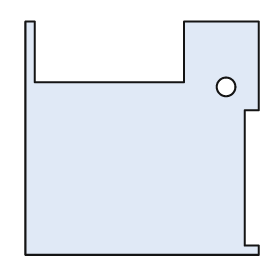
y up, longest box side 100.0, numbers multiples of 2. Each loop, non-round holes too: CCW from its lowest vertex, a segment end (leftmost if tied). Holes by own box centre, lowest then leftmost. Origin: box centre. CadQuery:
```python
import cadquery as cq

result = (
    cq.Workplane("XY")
    .moveTo(-50.0, -50.0)
    .lineTo(50.0, -50.0)
    .lineTo(50.0, -46.0)
    .lineTo(44.0, -46.0)
    .lineTo(44.0, 12.0)
    .lineTo(50.0, 12.0)
    .lineTo(50.0, 50.0)
    .lineTo(18.0, 50.0)
    .lineTo(18.0, 24.0)
    .lineTo(-46.0, 24.0)
    .lineTo(-46.0, 50.0)
    .lineTo(-50.0, 50.0)
    .close()
    .moveTo(36.0, 22.0)
    .circle(4.0)
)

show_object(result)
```